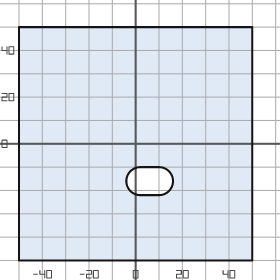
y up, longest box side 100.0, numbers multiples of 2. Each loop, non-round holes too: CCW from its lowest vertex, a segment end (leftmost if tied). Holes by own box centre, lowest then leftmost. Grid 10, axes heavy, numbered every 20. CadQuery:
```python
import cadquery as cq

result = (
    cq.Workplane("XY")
    .moveTo(-50.0, -50.0)
    .lineTo(50.0, -50.0)
    .lineTo(50.0, 50.0)
    .lineTo(-50.0, 50.0)
    .close()
    .moveTo(2.0, -22.0)
    .lineTo(10.0, -22.0)
    .threePointArc((16.0, -16.0), (10.0, -10.0))
    .lineTo(2.0, -10.0)
    .threePointArc((-4.0, -16.0), (2.0, -22.0))
    .close()
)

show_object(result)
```